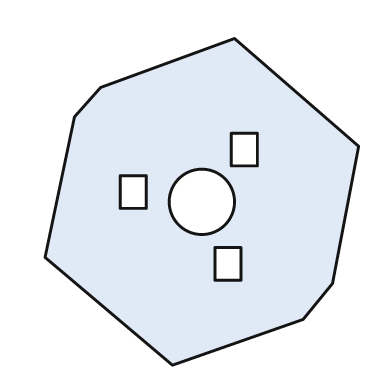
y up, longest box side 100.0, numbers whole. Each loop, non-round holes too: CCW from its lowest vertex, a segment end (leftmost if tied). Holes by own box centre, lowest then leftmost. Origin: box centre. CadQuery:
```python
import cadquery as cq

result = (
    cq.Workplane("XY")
    .moveTo(-9.0, -50.0)
    .lineTo(31.0, -36.0)
    .lineTo(40.0, -25.0)
    .lineTo(48.0, 17.0)
    .lineTo(10.0, 50.0)
    .lineTo(-31.0, 35.0)
    .lineTo(-39.0, 26.0)
    .lineTo(-48.0, -17.0)
    .close()
    .moveTo(4.0, -24.0)
    .lineTo(12.0, -24.0)
    .lineTo(12.0, -14.0)
    .lineTo(4.0, -14.0)
    .close()
    .moveTo(0.0, 0.0)
    .circle(10.0)
    .moveTo(-25.0, -2.0)
    .lineTo(-17.0, -2.0)
    .lineTo(-17.0, 8.0)
    .lineTo(-25.0, 8.0)
    .close()
    .moveTo(9.0, 11.0)
    .lineTo(17.0, 11.0)
    .lineTo(17.0, 21.0)
    .lineTo(9.0, 21.0)
    .close()
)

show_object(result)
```